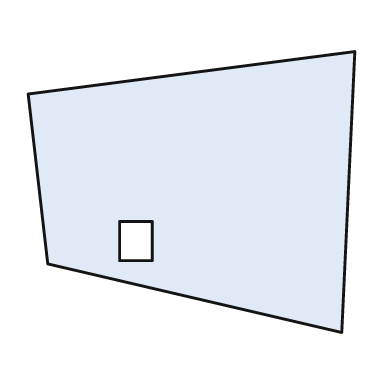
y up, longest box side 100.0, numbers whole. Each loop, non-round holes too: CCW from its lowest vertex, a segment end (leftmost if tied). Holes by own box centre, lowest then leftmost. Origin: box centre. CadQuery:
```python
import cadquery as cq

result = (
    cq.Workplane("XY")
    .moveTo(46.0, -43.0)
    .lineTo(50.0, 43.0)
    .lineTo(-50.0, 30.0)
    .lineTo(-44.0, -22.0)
    .close()
    .moveTo(-22.0, -21.0)
    .lineTo(-12.0, -21.0)
    .lineTo(-12.0, -9.0)
    .lineTo(-22.0, -9.0)
    .close()
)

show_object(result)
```